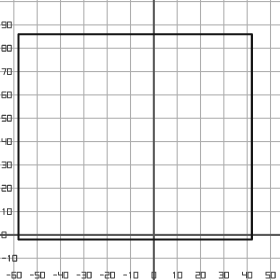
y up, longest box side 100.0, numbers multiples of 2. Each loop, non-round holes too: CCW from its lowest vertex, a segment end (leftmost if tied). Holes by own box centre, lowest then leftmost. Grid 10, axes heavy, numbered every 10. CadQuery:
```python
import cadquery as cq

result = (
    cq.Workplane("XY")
    .moveTo(-58.0, -2.0)
    .lineTo(42.0, -2.0)
    .lineTo(42.0, 86.0)
    .lineTo(-58.0, 86.0)
    .close()
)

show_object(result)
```